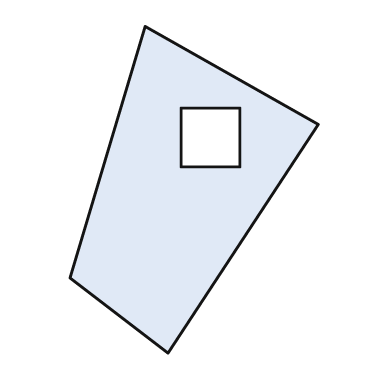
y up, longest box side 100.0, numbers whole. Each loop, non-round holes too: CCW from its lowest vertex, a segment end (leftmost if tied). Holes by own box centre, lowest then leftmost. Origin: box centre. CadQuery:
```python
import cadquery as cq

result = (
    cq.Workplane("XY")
    .moveTo(-8.0, -50.0)
    .lineTo(38.0, 20.0)
    .lineTo(-15.0, 50.0)
    .lineTo(-38.0, -27.0)
    .close()
    .moveTo(-4.0, 7.0)
    .lineTo(14.0, 7.0)
    .lineTo(14.0, 25.0)
    .lineTo(-4.0, 25.0)
    .close()
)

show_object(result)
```